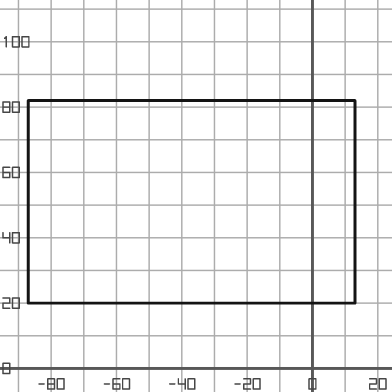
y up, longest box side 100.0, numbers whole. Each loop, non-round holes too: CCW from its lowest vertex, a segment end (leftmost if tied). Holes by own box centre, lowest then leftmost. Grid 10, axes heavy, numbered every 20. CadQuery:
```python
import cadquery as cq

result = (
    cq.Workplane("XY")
    .moveTo(-87.0, 20.0)
    .lineTo(13.0, 20.0)
    .lineTo(13.0, 82.0)
    .lineTo(-87.0, 82.0)
    .close()
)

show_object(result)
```